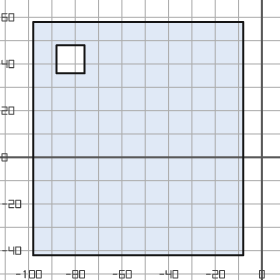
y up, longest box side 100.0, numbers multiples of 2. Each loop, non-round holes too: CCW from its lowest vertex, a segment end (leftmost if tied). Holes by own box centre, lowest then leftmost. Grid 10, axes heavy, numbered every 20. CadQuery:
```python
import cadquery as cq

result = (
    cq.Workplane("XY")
    .moveTo(-98.0, -42.0)
    .lineTo(-8.0, -42.0)
    .lineTo(-8.0, 58.0)
    .lineTo(-98.0, 58.0)
    .close()
    .moveTo(-88.0, 36.0)
    .lineTo(-76.0, 36.0)
    .lineTo(-76.0, 48.0)
    .lineTo(-88.0, 48.0)
    .close()
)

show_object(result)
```